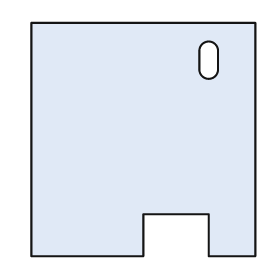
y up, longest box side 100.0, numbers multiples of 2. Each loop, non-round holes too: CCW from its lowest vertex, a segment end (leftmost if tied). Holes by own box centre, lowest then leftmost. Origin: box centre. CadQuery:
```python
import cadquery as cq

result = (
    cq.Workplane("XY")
    .moveTo(-48.0, -50.0)
    .lineTo(0.0, -50.0)
    .lineTo(0.0, -32.0)
    .lineTo(28.0, -32.0)
    .lineTo(28.0, -50.0)
    .lineTo(48.0, -50.0)
    .lineTo(48.0, 50.0)
    .lineTo(-48.0, 50.0)
    .close()
    .moveTo(24.0, 30.0)
    .threePointArc((28.0, 26.0), (32.0, 30.0))
    .lineTo(32.0, 38.0)
    .threePointArc((28.0, 42.0), (24.0, 38.0))
    .close()
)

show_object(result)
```